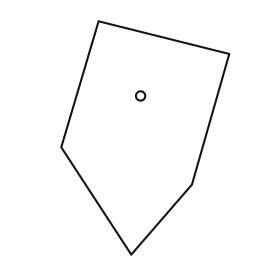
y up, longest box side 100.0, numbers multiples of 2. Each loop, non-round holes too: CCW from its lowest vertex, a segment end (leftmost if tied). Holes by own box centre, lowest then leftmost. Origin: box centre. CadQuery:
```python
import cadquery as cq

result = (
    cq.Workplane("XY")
    .moveTo(-6.0, -50.0)
    .lineTo(20.0, -20.0)
    .lineTo(36.0, 36.0)
    .lineTo(-20.0, 50.0)
    .lineTo(-36.0, -4.0)
    .close()
    .moveTo(-2.0, 18.0)
    .circle(2.0)
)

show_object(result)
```